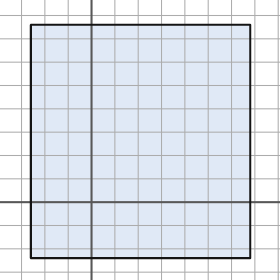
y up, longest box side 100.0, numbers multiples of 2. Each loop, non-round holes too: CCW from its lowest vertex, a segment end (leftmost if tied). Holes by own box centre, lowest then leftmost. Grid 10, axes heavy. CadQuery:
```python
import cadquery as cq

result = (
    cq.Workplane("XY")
    .moveTo(-26.0, -24.0)
    .lineTo(68.0, -24.0)
    .lineTo(68.0, 76.0)
    .lineTo(-26.0, 76.0)
    .close()
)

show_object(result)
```